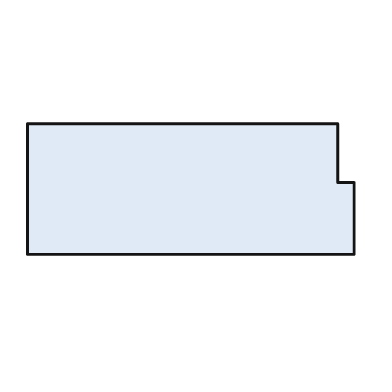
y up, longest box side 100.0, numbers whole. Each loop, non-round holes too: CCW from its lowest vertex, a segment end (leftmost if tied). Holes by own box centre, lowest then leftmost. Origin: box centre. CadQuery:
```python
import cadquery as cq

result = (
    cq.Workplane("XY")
    .moveTo(-50.0, -20.0)
    .lineTo(50.0, -20.0)
    .lineTo(50.0, 2.0)
    .lineTo(45.0, 2.0)
    .lineTo(45.0, 20.0)
    .lineTo(-50.0, 20.0)
    .close()
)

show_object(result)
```